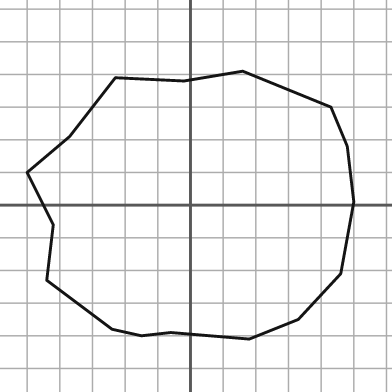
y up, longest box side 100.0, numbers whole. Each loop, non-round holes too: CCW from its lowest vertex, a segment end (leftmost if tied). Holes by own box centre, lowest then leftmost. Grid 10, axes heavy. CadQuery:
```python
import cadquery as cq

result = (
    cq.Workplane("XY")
    .moveTo(18.0, -41.0)
    .lineTo(33.0, -35.0)
    .lineTo(46.0, -21.0)
    .lineTo(50.0, 1.0)
    .lineTo(48.0, 18.0)
    .lineTo(43.0, 30.0)
    .lineTo(16.0, 41.0)
    .lineTo(-2.0, 38.0)
    .lineTo(-23.0, 39.0)
    .lineTo(-37.0, 21.0)
    .lineTo(-50.0, 10.0)
    .lineTo(-42.0, -6.0)
    .lineTo(-44.0, -23.0)
    .lineTo(-24.0, -38.0)
    .lineTo(-15.0, -40.0)
    .lineTo(-6.0, -39.0)
    .close()
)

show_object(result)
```